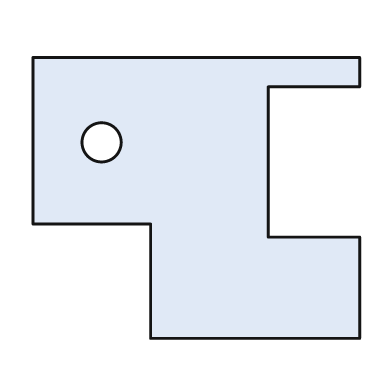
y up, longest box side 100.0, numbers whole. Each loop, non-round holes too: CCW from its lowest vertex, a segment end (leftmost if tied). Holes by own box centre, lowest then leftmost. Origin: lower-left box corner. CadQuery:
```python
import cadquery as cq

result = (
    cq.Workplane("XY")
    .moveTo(36.0, 0.0)
    .lineTo(100.0, 0.0)
    .lineTo(100.0, 31.0)
    .lineTo(72.0, 31.0)
    .lineTo(72.0, 77.0)
    .lineTo(100.0, 77.0)
    .lineTo(100.0, 86.0)
    .lineTo(0.0, 86.0)
    .lineTo(0.0, 35.0)
    .lineTo(36.0, 35.0)
    .close()
    .moveTo(21.0, 60.0)
    .circle(6.0)
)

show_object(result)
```